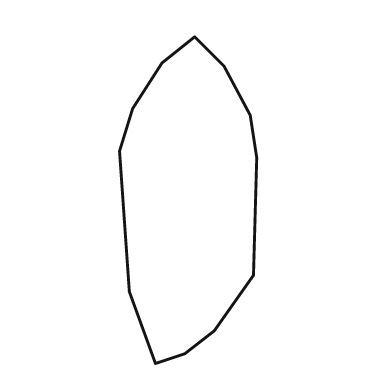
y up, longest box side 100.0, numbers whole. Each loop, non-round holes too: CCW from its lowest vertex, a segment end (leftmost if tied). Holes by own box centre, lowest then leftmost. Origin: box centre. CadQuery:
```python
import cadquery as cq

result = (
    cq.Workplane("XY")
    .moveTo(-10.0, -50.0)
    .lineTo(-1.0, -47.0)
    .lineTo(8.0, -40.0)
    .lineTo(20.0, -23.0)
    .lineTo(21.0, 13.0)
    .lineTo(19.0, 26.0)
    .lineTo(11.0, 41.0)
    .lineTo(2.0, 50.0)
    .lineTo(-8.0, 42.0)
    .lineTo(-17.0, 28.0)
    .lineTo(-21.0, 15.0)
    .lineTo(-18.0, -28.0)
    .close()
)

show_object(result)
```